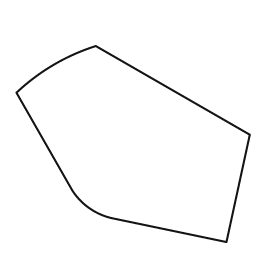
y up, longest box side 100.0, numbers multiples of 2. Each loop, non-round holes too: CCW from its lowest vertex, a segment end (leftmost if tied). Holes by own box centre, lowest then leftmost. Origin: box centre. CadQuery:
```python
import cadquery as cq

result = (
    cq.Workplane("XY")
    .moveTo(40.0, -42.0)
    .lineTo(50.0, 4.0)
    .lineTo(-16.0, 42.0)
    .threePointArc((-34.0, 34.0), (-50.0, 22.0))
    .lineTo(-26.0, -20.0)
    .threePointArc((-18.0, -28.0), (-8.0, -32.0))
    .close()
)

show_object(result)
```